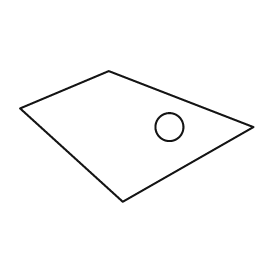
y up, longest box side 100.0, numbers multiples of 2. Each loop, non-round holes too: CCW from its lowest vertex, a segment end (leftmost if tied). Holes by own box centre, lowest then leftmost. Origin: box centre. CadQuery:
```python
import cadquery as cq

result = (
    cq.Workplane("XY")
    .moveTo(-6.0, -28.0)
    .lineTo(50.0, 4.0)
    .lineTo(-12.0, 28.0)
    .lineTo(-50.0, 12.0)
    .close()
    .moveTo(14.0, 4.0)
    .circle(6.0)
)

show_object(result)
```